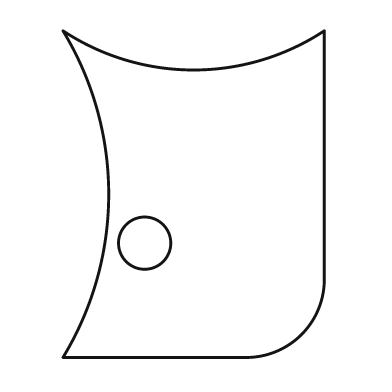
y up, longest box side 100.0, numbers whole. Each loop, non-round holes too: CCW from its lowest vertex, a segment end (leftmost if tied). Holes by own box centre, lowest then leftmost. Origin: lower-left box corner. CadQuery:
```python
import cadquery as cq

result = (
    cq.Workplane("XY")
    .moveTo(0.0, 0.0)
    .lineTo(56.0, 0.0)
    .threePointArc((73.0, 7.0), (80.0, 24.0))
    .lineTo(80.0, 100.0)
    .threePointArc((40.0, 88.0), (0.0, 100.0))
    .threePointArc((14.0, 50.0), (0.0, 0.0))
    .close()
    .moveTo(25.0, 35.0)
    .circle(8.0)
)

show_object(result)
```